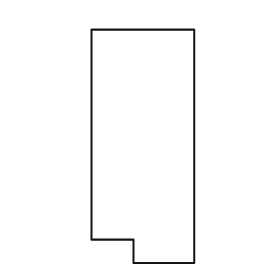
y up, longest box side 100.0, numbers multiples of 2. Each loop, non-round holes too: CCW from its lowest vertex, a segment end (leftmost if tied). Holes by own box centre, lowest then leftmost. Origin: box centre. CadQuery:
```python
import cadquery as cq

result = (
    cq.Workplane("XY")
    .moveTo(-4.0, -50.0)
    .lineTo(22.0, -50.0)
    .lineTo(22.0, 50.0)
    .lineTo(-22.0, 50.0)
    .lineTo(-22.0, -40.0)
    .lineTo(-4.0, -40.0)
    .close()
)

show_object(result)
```